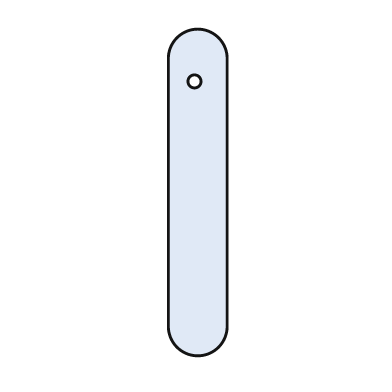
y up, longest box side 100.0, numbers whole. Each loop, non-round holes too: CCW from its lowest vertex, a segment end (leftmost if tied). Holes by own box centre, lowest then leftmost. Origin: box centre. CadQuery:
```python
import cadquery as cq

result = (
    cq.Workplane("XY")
    .moveTo(-9.0, -41.0)
    .threePointArc((0.0, -50.0), (9.0, -41.0))
    .lineTo(9.0, 41.0)
    .threePointArc((0.0, 50.0), (-9.0, 41.0))
    .close()
    .moveTo(-1.0, 34.0)
    .circle(2.0)
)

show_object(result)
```